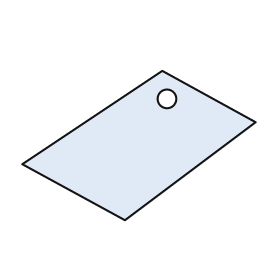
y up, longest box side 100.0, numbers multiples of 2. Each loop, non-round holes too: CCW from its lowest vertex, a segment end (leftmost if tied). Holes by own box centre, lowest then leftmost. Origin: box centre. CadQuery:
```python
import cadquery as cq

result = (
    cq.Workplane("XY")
    .moveTo(-6.0, -32.0)
    .lineTo(50.0, 10.0)
    .lineTo(10.0, 32.0)
    .lineTo(-50.0, -8.0)
    .close()
    .moveTo(12.0, 20.0)
    .circle(4.0)
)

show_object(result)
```